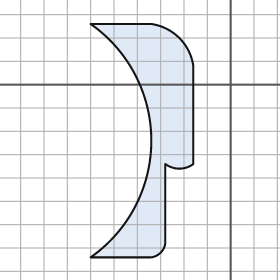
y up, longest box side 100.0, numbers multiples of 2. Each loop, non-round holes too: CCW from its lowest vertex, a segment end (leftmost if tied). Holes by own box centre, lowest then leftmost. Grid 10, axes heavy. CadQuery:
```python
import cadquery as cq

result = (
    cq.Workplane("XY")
    .moveTo(-60.0, -74.0)
    .lineTo(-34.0, -74.0)
    .threePointArc((-30.0, -72.0), (-28.0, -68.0))
    .lineTo(-28.0, -34.0)
    .threePointArc((-22.0, -36.0), (-16.0, -34.0))
    .lineTo(-16.0, 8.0)
    .threePointArc((-22.0, 20.0), (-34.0, 26.0))
    .lineTo(-60.0, 26.0)
    .threePointArc((-34.0, -24.0), (-60.0, -74.0))
    .close()
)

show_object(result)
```